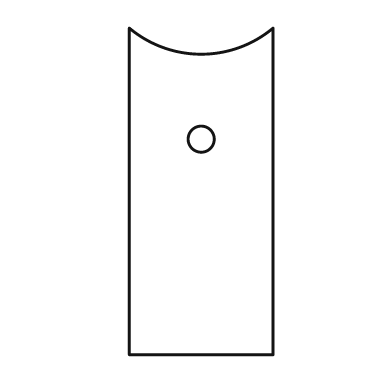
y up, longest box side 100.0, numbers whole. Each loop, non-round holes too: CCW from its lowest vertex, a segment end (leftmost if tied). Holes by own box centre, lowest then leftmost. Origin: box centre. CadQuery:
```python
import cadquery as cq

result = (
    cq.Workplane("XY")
    .moveTo(-22.0, -50.0)
    .lineTo(22.0, -50.0)
    .lineTo(22.0, 50.0)
    .threePointArc((0.0, 42.0), (-22.0, 50.0))
    .close()
    .moveTo(0.0, 16.0)
    .circle(4.0)
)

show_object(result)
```